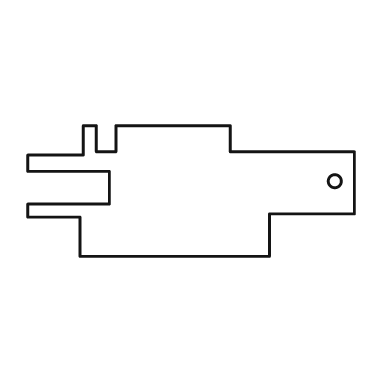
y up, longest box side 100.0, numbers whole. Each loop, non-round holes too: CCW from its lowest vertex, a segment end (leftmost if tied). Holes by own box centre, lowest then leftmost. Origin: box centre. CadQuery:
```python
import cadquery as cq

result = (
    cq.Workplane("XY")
    .moveTo(-34.0, -20.0)
    .lineTo(24.0, -20.0)
    .lineTo(24.0, -7.0)
    .lineTo(50.0, -7.0)
    .lineTo(50.0, 12.0)
    .lineTo(12.0, 12.0)
    .lineTo(12.0, 20.0)
    .lineTo(-23.0, 20.0)
    .lineTo(-23.0, 12.0)
    .lineTo(-29.0, 12.0)
    .lineTo(-29.0, 20.0)
    .lineTo(-33.0, 20.0)
    .lineTo(-33.0, 11.0)
    .lineTo(-50.0, 11.0)
    .lineTo(-50.0, 6.0)
    .lineTo(-25.0, 6.0)
    .lineTo(-25.0, -4.0)
    .lineTo(-50.0, -4.0)
    .lineTo(-50.0, -8.0)
    .lineTo(-34.0, -8.0)
    .close()
    .moveTo(44.0, 3.0)
    .circle(2.0)
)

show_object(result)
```